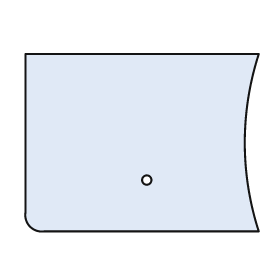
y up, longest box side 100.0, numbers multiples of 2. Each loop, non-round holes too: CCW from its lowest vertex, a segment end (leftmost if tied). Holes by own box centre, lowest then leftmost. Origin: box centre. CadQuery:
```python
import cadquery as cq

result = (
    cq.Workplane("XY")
    .moveTo(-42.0, -38.0)
    .lineTo(50.0, -38.0)
    .threePointArc((44.0, 0.0), (50.0, 38.0))
    .lineTo(-50.0, 38.0)
    .lineTo(-50.0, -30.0)
    .threePointArc((-48.0, -36.0), (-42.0, -38.0))
    .close()
    .moveTo(2.0, -16.0)
    .circle(2.0)
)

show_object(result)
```